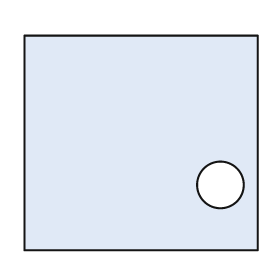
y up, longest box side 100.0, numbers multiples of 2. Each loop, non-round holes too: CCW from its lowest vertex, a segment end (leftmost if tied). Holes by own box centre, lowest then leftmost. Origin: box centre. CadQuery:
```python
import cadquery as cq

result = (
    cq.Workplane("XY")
    .moveTo(-50.0, -46.0)
    .lineTo(50.0, -46.0)
    .lineTo(50.0, 46.0)
    .lineTo(-50.0, 46.0)
    .close()
    .moveTo(34.0, -18.0)
    .circle(10.0)
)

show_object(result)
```